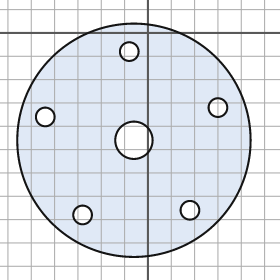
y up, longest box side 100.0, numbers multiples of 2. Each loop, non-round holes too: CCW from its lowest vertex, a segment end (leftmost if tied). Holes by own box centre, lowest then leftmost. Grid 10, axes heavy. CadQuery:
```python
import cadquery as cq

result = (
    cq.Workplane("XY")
    .moveTo(-6.0, -46.0)
    .circle(50.0)
    .moveTo(-28.0, -78.0)
    .circle(4.0)
    .moveTo(18.0, -76.0)
    .circle(4.0)
    .moveTo(-6.0, -46.0)
    .circle(8.0)
    .moveTo(-44.0, -36.0)
    .circle(4.0)
    .moveTo(30.0, -32.0)
    .circle(4.0)
    .moveTo(-8.0, -8.0)
    .circle(4.0)
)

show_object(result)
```